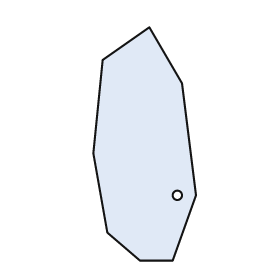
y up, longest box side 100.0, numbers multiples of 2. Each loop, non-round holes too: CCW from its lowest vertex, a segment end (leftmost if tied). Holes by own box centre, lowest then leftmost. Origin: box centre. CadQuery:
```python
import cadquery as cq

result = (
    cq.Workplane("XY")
    .moveTo(-2.0, -50.0)
    .lineTo(12.0, -50.0)
    .lineTo(22.0, -22.0)
    .lineTo(16.0, 26.0)
    .lineTo(2.0, 50.0)
    .lineTo(-18.0, 36.0)
    .lineTo(-22.0, -4.0)
    .lineTo(-16.0, -38.0)
    .close()
    .moveTo(14.0, -22.0)
    .circle(2.0)
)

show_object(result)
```